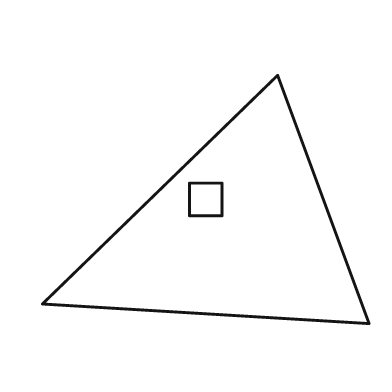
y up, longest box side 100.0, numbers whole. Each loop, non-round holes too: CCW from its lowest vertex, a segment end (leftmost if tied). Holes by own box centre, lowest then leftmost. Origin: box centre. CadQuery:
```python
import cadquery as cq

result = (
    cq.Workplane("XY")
    .moveTo(50.0, -38.0)
    .lineTo(22.0, 38.0)
    .lineTo(-50.0, -32.0)
    .close()
    .moveTo(-5.0, -5.0)
    .lineTo(5.0, -5.0)
    .lineTo(5.0, 5.0)
    .lineTo(-5.0, 5.0)
    .close()
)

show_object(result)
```